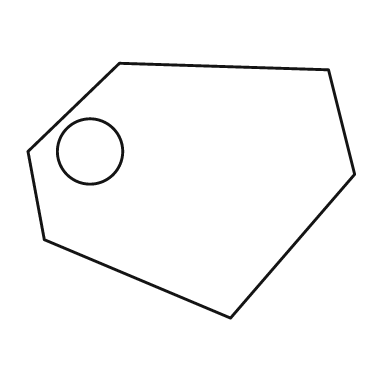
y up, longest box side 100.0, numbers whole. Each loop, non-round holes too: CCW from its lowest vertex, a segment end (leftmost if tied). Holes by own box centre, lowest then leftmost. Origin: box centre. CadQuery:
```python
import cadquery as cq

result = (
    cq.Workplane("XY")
    .moveTo(12.0, -39.0)
    .lineTo(50.0, 5.0)
    .lineTo(42.0, 37.0)
    .lineTo(-22.0, 39.0)
    .lineTo(-50.0, 12.0)
    .lineTo(-45.0, -15.0)
    .close()
    .moveTo(-31.0, 12.0)
    .circle(10.0)
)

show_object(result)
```